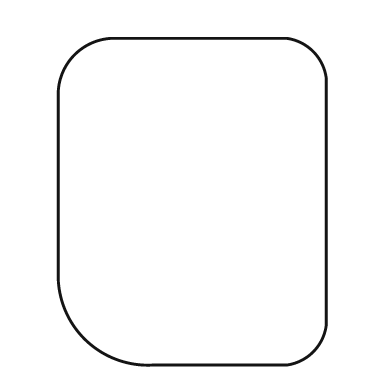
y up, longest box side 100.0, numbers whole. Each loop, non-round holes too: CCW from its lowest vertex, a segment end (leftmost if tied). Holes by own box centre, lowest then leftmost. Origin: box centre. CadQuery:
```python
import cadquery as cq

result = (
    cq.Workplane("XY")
    .moveTo(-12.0, -50.0)
    .lineTo(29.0, -50.0)
    .threePointArc((37.0, -46.0), (41.0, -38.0))
    .lineTo(41.0, 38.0)
    .threePointArc((37.0, 46.0), (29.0, 50.0))
    .lineTo(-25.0, 50.0)
    .threePointArc((-36.0, 45.0), (-41.0, 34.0))
    .lineTo(-41.0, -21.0)
    .threePointArc((-33.0, -42.0), (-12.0, -50.0))
    .close()
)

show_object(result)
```